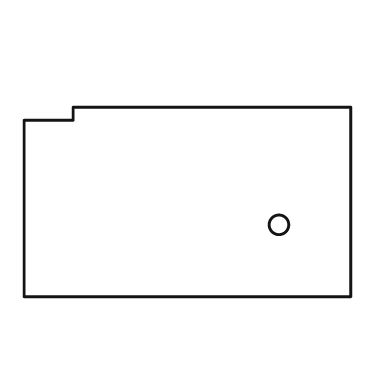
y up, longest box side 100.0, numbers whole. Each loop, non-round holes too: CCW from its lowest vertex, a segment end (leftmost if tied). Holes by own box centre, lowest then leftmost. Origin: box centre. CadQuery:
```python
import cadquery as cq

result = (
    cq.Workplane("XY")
    .moveTo(-50.0, -29.0)
    .lineTo(50.0, -29.0)
    .lineTo(50.0, 29.0)
    .lineTo(-35.0, 29.0)
    .lineTo(-35.0, 25.0)
    .lineTo(-50.0, 25.0)
    .close()
    .moveTo(28.0, -7.0)
    .circle(3.0)
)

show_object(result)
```